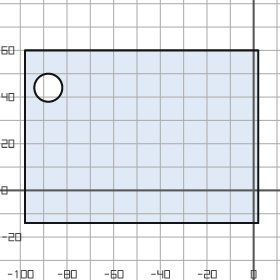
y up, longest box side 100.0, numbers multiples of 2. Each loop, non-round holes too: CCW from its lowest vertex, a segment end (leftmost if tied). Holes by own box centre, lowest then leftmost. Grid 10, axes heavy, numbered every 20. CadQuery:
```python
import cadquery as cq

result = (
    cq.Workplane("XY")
    .moveTo(-98.0, -14.0)
    .lineTo(2.0, -14.0)
    .lineTo(2.0, 60.0)
    .lineTo(-98.0, 60.0)
    .close()
    .moveTo(-88.0, 44.0)
    .circle(6.0)
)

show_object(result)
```